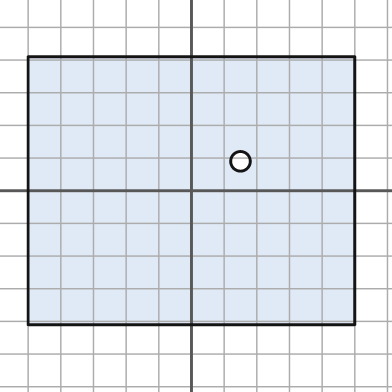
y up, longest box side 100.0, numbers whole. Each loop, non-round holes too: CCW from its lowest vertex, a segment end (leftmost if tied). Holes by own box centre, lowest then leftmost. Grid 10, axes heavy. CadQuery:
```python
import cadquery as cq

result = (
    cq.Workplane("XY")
    .moveTo(-50.0, -41.0)
    .lineTo(50.0, -41.0)
    .lineTo(50.0, 41.0)
    .lineTo(-50.0, 41.0)
    .close()
    .moveTo(15.0, 9.0)
    .circle(3.0)
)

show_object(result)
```